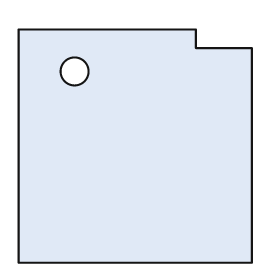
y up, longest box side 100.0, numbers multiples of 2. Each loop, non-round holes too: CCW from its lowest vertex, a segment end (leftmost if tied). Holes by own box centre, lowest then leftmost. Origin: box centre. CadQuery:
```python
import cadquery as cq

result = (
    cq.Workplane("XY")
    .moveTo(-50.0, -50.0)
    .lineTo(50.0, -50.0)
    .lineTo(50.0, 42.0)
    .lineTo(26.0, 42.0)
    .lineTo(26.0, 50.0)
    .lineTo(-50.0, 50.0)
    .close()
    .moveTo(-26.0, 32.0)
    .circle(6.0)
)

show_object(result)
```